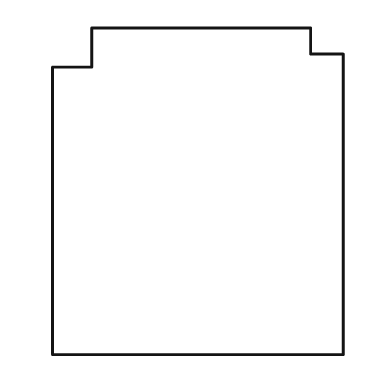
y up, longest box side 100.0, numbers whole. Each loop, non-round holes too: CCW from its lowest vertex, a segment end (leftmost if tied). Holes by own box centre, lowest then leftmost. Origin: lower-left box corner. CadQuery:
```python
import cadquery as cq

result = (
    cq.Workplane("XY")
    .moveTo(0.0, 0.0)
    .lineTo(89.0, 0.0)
    .lineTo(89.0, 92.0)
    .lineTo(79.0, 92.0)
    .lineTo(79.0, 100.0)
    .lineTo(12.0, 100.0)
    .lineTo(12.0, 88.0)
    .lineTo(0.0, 88.0)
    .close()
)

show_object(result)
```